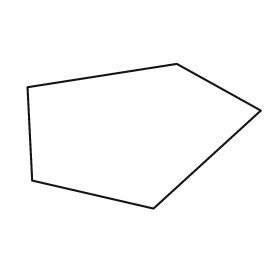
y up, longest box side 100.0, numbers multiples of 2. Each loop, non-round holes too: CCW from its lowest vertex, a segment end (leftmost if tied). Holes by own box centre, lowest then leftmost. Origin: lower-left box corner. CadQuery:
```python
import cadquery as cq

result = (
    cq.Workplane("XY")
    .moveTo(54.0, 0.0)
    .lineTo(100.0, 42.0)
    .lineTo(64.0, 62.0)
    .lineTo(0.0, 52.0)
    .lineTo(2.0, 12.0)
    .close()
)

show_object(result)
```